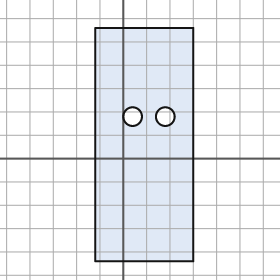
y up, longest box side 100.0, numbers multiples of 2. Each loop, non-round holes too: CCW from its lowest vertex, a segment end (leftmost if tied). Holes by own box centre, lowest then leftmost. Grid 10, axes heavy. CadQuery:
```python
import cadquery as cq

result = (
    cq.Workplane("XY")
    .moveTo(-12.0, -44.0)
    .lineTo(30.0, -44.0)
    .lineTo(30.0, 56.0)
    .lineTo(-12.0, 56.0)
    .close()
    .moveTo(4.0, 18.0)
    .circle(4.0)
    .moveTo(18.0, 18.0)
    .circle(4.0)
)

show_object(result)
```